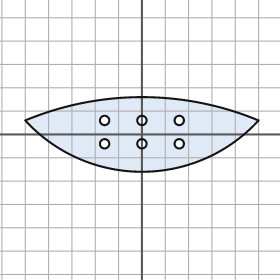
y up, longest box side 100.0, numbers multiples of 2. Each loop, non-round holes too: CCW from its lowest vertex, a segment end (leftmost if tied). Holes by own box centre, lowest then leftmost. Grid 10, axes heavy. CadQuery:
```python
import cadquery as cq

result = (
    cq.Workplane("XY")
    .moveTo(-50.0, 6.0)
    .threePointArc((0.0, -16.0), (50.0, 6.0))
    .threePointArc((0.0, 16.0), (-50.0, 6.0))
    .close()
    .moveTo(-16.0, -4.0)
    .circle(2.0)
    .moveTo(0.0, -4.0)
    .circle(2.0)
    .moveTo(16.0, -4.0)
    .circle(2.0)
    .moveTo(-16.0, 6.0)
    .circle(2.0)
    .moveTo(0.0, 6.0)
    .circle(2.0)
    .moveTo(16.0, 6.0)
    .circle(2.0)
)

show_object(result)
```